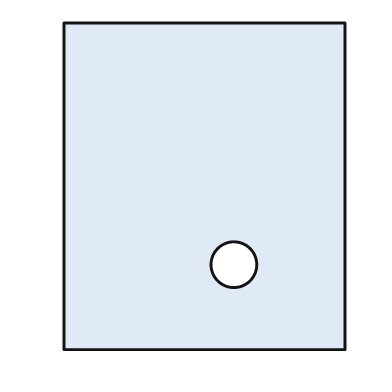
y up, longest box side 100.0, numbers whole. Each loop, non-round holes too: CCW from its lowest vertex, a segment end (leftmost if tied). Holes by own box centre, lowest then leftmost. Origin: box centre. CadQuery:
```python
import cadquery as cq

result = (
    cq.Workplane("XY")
    .moveTo(-43.0, -50.0)
    .lineTo(43.0, -50.0)
    .lineTo(43.0, 50.0)
    .lineTo(-43.0, 50.0)
    .close()
    .moveTo(9.0, -24.0)
    .circle(7.0)
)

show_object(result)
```